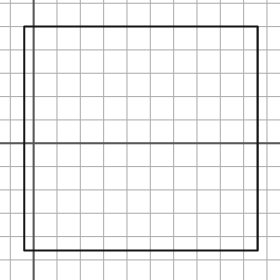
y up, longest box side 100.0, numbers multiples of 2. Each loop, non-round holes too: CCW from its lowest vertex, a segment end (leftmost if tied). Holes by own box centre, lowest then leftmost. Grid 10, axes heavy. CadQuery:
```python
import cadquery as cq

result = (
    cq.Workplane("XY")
    .moveTo(-4.0, -46.0)
    .lineTo(96.0, -46.0)
    .lineTo(96.0, 50.0)
    .lineTo(-4.0, 50.0)
    .close()
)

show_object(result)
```